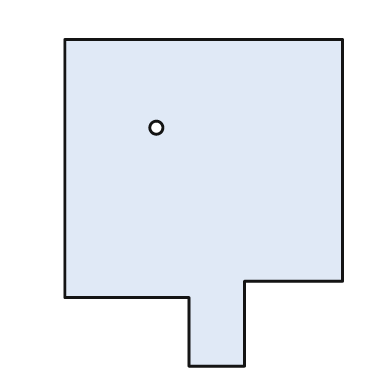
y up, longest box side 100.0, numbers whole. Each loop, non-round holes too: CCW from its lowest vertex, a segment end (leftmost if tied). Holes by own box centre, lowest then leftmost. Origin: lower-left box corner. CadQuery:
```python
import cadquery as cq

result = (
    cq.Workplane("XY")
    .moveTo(38.0, 0.0)
    .lineTo(55.0, 0.0)
    .lineTo(55.0, 26.0)
    .lineTo(85.0, 26.0)
    .lineTo(85.0, 100.0)
    .lineTo(0.0, 100.0)
    .lineTo(0.0, 21.0)
    .lineTo(38.0, 21.0)
    .close()
    .moveTo(28.0, 73.0)
    .circle(2.0)
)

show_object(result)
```